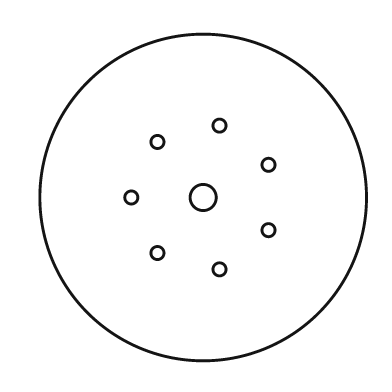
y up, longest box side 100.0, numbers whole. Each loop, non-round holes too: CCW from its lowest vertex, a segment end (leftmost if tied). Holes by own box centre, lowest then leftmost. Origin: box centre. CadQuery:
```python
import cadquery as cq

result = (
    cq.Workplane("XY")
    .moveTo(0.0, 0.0)
    .circle(50.0)
    .moveTo(5.0, -22.0)
    .circle(2.0)
    .moveTo(-14.0, -17.0)
    .circle(2.0)
    .moveTo(20.0, -10.0)
    .circle(2.0)
    .moveTo(-22.0, 0.0)
    .circle(2.0)
    .moveTo(0.0, 0.0)
    .circle(4.0)
    .moveTo(20.0, 10.0)
    .circle(2.0)
    .moveTo(-14.0, 17.0)
    .circle(2.0)
    .moveTo(5.0, 22.0)
    .circle(2.0)
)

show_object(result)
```